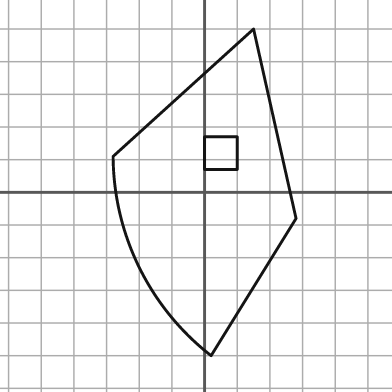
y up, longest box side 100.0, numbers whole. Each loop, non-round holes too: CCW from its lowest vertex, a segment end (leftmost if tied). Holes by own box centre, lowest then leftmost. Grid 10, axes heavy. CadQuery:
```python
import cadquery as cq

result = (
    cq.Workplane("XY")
    .moveTo(2.0, -50.0)
    .lineTo(28.0, -8.0)
    .lineTo(15.0, 50.0)
    .lineTo(-28.0, 11.0)
    .threePointArc((-20.0, -23.0), (2.0, -50.0))
    .close()
    .moveTo(0.0, 7.0)
    .lineTo(10.0, 7.0)
    .lineTo(10.0, 17.0)
    .lineTo(0.0, 17.0)
    .close()
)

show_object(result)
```